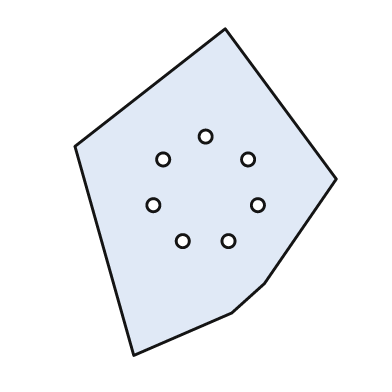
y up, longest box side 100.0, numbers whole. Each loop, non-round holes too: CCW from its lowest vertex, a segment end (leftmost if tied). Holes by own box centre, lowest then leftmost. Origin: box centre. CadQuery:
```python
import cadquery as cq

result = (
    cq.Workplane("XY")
    .moveTo(-22.0, -50.0)
    .lineTo(8.0, -37.0)
    .lineTo(18.0, -28.0)
    .lineTo(40.0, 4.0)
    .lineTo(6.0, 50.0)
    .lineTo(-40.0, 14.0)
    .close()
    .moveTo(-7.0, -15.0)
    .circle(2.0)
    .moveTo(7.0, -15.0)
    .circle(2.0)
    .moveTo(-16.0, -4.0)
    .circle(2.0)
    .moveTo(16.0, -4.0)
    .circle(2.0)
    .moveTo(-13.0, 10.0)
    .circle(2.0)
    .moveTo(13.0, 10.0)
    .circle(2.0)
    .moveTo(0.0, 17.0)
    .circle(2.0)
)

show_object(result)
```